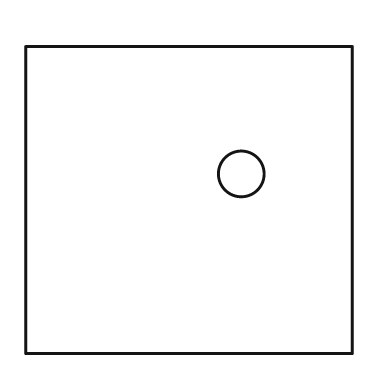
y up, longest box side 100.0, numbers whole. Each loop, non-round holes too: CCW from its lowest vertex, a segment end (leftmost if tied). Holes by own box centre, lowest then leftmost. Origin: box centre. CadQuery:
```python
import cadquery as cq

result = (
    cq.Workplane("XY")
    .moveTo(-50.0, -47.0)
    .lineTo(50.0, -47.0)
    .lineTo(50.0, 47.0)
    .lineTo(-50.0, 47.0)
    .close()
    .moveTo(16.0, 8.0)
    .circle(7.0)
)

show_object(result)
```